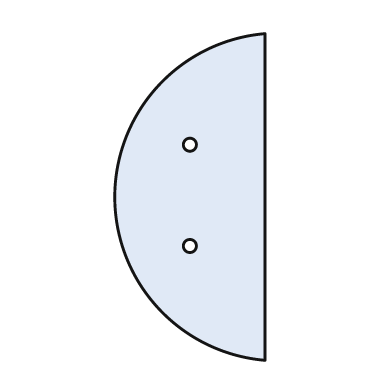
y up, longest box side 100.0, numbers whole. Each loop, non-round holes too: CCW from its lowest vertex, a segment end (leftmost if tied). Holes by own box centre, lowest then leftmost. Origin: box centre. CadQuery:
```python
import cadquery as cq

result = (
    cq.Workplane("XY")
    .moveTo(23.0, -50.0)
    .lineTo(23.0, 50.0)
    .threePointArc((-23.0, 0.0), (23.0, -50.0))
    .close()
    .moveTo(0.0, -15.0)
    .circle(2.0)
    .moveTo(0.0, 16.0)
    .circle(2.0)
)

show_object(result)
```